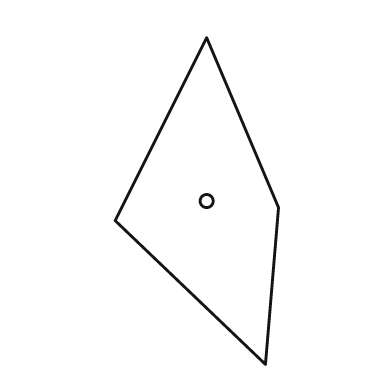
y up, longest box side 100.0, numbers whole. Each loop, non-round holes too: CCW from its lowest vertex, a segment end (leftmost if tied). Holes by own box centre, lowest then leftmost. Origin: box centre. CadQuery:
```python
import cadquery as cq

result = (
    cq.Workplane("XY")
    .moveTo(21.0, -50.0)
    .lineTo(25.0, -2.0)
    .lineTo(3.0, 50.0)
    .lineTo(-25.0, -6.0)
    .close()
    .moveTo(3.0, 0.0)
    .circle(2.0)
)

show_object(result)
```